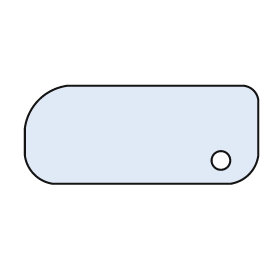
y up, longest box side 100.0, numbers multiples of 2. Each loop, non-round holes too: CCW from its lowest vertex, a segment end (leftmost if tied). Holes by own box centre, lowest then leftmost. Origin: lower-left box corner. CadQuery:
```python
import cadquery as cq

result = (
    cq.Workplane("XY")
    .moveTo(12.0, 0.0)
    .lineTo(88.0, 0.0)
    .threePointArc((96.0, 4.0), (100.0, 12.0))
    .lineTo(100.0, 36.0)
    .threePointArc((98.0, 40.0), (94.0, 42.0))
    .lineTo(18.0, 42.0)
    .threePointArc((6.0, 36.0), (0.0, 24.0))
    .lineTo(0.0, 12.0)
    .threePointArc((4.0, 4.0), (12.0, 0.0))
    .close()
    .moveTo(84.0, 10.0)
    .circle(4.0)
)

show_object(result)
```